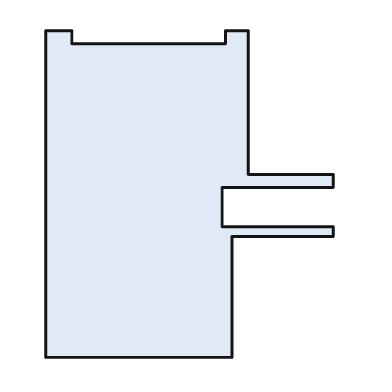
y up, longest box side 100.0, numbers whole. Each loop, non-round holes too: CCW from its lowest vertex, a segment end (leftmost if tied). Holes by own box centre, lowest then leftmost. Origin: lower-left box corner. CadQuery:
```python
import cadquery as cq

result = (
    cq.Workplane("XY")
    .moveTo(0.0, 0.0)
    .lineTo(57.0, 0.0)
    .lineTo(57.0, 37.0)
    .lineTo(88.0, 37.0)
    .lineTo(88.0, 40.0)
    .lineTo(54.0, 40.0)
    .lineTo(54.0, 52.0)
    .lineTo(88.0, 52.0)
    .lineTo(88.0, 56.0)
    .lineTo(62.0, 56.0)
    .lineTo(62.0, 100.0)
    .lineTo(55.0, 100.0)
    .lineTo(55.0, 96.0)
    .lineTo(8.0, 96.0)
    .lineTo(8.0, 100.0)
    .lineTo(0.0, 100.0)
    .close()
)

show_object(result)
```